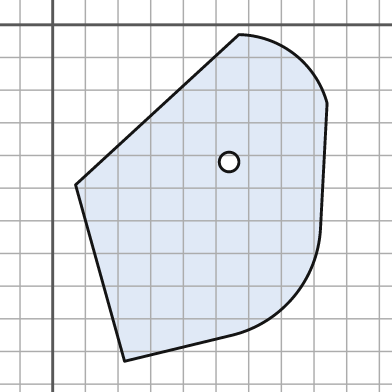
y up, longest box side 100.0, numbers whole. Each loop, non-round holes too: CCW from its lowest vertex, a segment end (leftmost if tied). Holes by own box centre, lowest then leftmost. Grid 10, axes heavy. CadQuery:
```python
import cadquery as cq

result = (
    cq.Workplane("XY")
    .moveTo(22.0, -103.0)
    .lineTo(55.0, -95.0)
    .threePointArc((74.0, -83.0), (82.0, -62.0))
    .lineTo(84.0, -24.0)
    .threePointArc((74.0, -9.0), (57.0, -3.0))
    .lineTo(7.0, -49.0)
    .close()
    .moveTo(54.0, -42.0)
    .circle(3.0)
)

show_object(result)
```